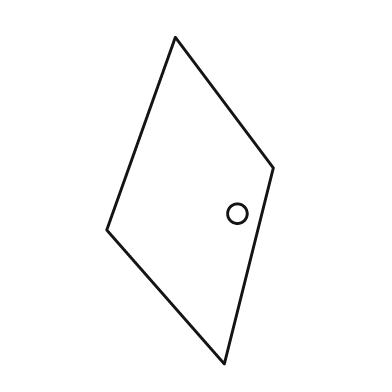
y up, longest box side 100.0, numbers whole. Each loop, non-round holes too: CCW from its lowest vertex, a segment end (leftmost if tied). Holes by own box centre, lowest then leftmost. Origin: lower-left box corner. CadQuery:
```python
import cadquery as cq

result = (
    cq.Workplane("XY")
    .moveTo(36.0, 0.0)
    .lineTo(51.0, 60.0)
    .lineTo(21.0, 100.0)
    .lineTo(0.0, 41.0)
    .close()
    .moveTo(40.0, 46.0)
    .circle(3.0)
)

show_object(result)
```